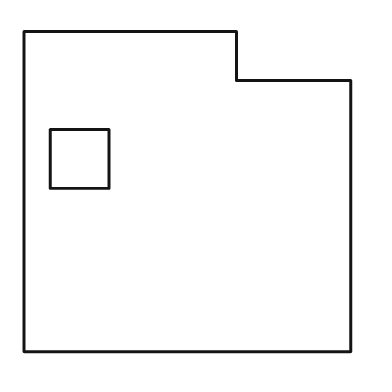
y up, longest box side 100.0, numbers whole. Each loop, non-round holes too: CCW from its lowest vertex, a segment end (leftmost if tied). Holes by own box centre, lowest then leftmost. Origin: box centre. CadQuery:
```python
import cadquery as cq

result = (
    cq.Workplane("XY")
    .moveTo(-50.0, -49.0)
    .lineTo(50.0, -49.0)
    .lineTo(50.0, 34.0)
    .lineTo(15.0, 34.0)
    .lineTo(15.0, 49.0)
    .lineTo(-50.0, 49.0)
    .close()
    .moveTo(-42.0, 1.0)
    .lineTo(-24.0, 1.0)
    .lineTo(-24.0, 19.0)
    .lineTo(-42.0, 19.0)
    .close()
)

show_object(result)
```